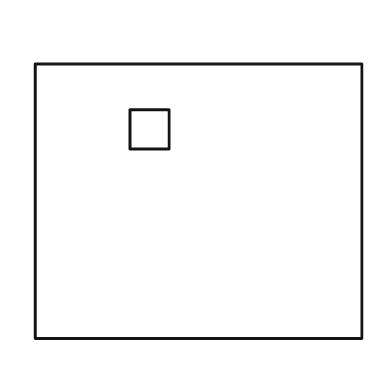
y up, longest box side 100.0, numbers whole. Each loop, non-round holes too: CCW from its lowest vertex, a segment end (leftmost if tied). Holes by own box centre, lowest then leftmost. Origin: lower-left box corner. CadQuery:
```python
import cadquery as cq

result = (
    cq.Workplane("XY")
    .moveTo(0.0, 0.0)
    .lineTo(100.0, 0.0)
    .lineTo(100.0, 84.0)
    .lineTo(0.0, 84.0)
    .close()
    .moveTo(29.0, 58.0)
    .lineTo(41.0, 58.0)
    .lineTo(41.0, 70.0)
    .lineTo(29.0, 70.0)
    .close()
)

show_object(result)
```